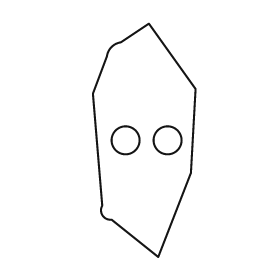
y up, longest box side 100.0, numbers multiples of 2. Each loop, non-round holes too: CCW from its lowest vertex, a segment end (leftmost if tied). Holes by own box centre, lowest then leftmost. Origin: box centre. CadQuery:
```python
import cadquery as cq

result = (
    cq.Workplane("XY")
    .moveTo(6.0, -50.0)
    .lineTo(20.0, -14.0)
    .lineTo(22.0, 22.0)
    .lineTo(2.0, 50.0)
    .lineTo(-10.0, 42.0)
    .threePointArc((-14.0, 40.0), (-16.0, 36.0))
    .lineTo(-22.0, 20.0)
    .lineTo(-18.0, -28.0)
    .threePointArc((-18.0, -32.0), (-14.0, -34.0))
    .close()
    .moveTo(-8.0, 0.0)
    .circle(6.0)
    .moveTo(10.0, 0.0)
    .circle(6.0)
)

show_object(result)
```